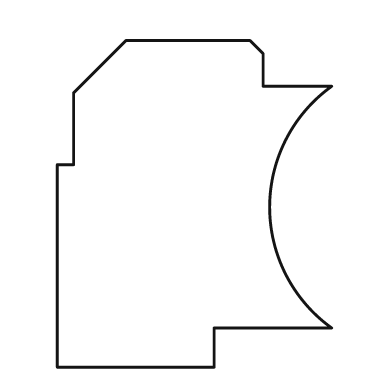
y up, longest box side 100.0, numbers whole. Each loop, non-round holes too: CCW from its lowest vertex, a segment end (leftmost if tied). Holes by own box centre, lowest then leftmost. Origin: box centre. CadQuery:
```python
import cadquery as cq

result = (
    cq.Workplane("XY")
    .moveTo(-42.0, -50.0)
    .lineTo(6.0, -50.0)
    .lineTo(6.0, -38.0)
    .lineTo(42.0, -38.0)
    .threePointArc((23.0, -1.0), (42.0, 36.0))
    .lineTo(21.0, 36.0)
    .lineTo(21.0, 46.0)
    .lineTo(17.0, 50.0)
    .lineTo(-21.0, 50.0)
    .lineTo(-37.0, 34.0)
    .lineTo(-37.0, 12.0)
    .lineTo(-42.0, 12.0)
    .close()
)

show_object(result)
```